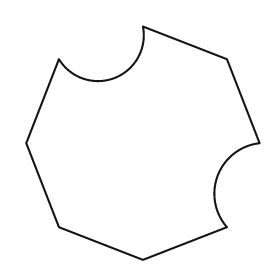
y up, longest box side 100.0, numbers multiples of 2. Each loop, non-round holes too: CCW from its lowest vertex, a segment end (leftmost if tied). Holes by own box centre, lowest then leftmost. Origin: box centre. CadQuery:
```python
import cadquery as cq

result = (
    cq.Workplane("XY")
    .moveTo(0.0, -50.0)
    .lineTo(36.0, -36.0)
    .threePointArc((32.0, -14.0), (50.0, 0.0))
    .lineTo(36.0, 36.0)
    .lineTo(0.0, 50.0)
    .threePointArc((-12.0, 28.0), (-36.0, 36.0))
    .lineTo(-50.0, 0.0)
    .lineTo(-36.0, -36.0)
    .close()
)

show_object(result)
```